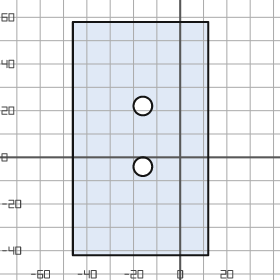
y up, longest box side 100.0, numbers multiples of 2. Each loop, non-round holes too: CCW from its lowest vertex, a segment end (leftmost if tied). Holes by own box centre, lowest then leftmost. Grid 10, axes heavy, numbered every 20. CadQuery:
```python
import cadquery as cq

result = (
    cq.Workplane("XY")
    .moveTo(-46.0, -42.0)
    .lineTo(12.0, -42.0)
    .lineTo(12.0, 58.0)
    .lineTo(-46.0, 58.0)
    .close()
    .moveTo(-16.0, -4.0)
    .circle(4.0)
    .moveTo(-16.0, 22.0)
    .circle(4.0)
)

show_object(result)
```